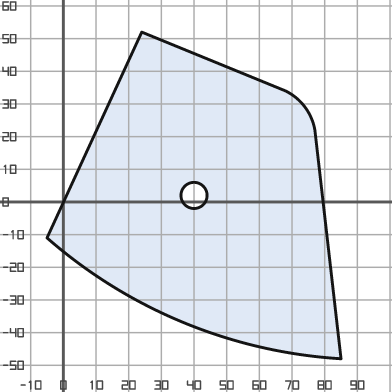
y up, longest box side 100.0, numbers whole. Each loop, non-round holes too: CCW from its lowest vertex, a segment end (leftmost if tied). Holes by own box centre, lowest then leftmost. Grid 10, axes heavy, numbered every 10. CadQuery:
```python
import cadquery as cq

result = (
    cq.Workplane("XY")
    .moveTo(85.0, -48.0)
    .lineTo(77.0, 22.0)
    .threePointArc((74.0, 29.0), (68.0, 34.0))
    .lineTo(24.0, 52.0)
    .lineTo(-5.0, -11.0)
    .threePointArc((37.0, -37.0), (85.0, -48.0))
    .close()
    .moveTo(40.0, 2.0)
    .circle(4.0)
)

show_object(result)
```